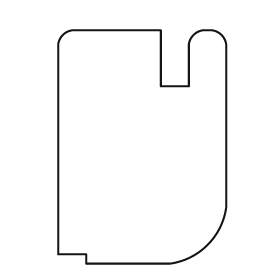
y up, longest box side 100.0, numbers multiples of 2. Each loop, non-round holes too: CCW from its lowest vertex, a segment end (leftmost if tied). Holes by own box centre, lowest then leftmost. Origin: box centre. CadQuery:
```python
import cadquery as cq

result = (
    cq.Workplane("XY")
    .moveTo(-24.0, -50.0)
    .lineTo(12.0, -50.0)
    .threePointArc((28.0, -42.0), (36.0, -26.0))
    .lineTo(36.0, 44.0)
    .threePointArc((34.0, 48.0), (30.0, 50.0))
    .lineTo(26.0, 50.0)
    .threePointArc((22.0, 48.0), (20.0, 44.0))
    .lineTo(20.0, 26.0)
    .lineTo(8.0, 26.0)
    .lineTo(8.0, 50.0)
    .lineTo(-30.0, 50.0)
    .threePointArc((-34.0, 48.0), (-36.0, 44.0))
    .lineTo(-36.0, -46.0)
    .lineTo(-24.0, -46.0)
    .close()
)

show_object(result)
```